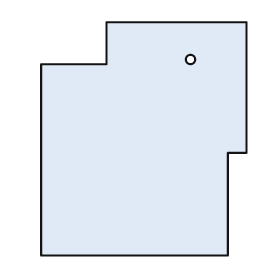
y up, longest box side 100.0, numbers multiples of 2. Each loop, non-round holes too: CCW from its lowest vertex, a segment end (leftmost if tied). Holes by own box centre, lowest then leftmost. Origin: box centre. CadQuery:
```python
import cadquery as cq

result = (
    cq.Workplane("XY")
    .moveTo(-44.0, -50.0)
    .lineTo(36.0, -50.0)
    .lineTo(36.0, -6.0)
    .lineTo(44.0, -6.0)
    .lineTo(44.0, 50.0)
    .lineTo(-16.0, 50.0)
    .lineTo(-16.0, 32.0)
    .lineTo(-44.0, 32.0)
    .close()
    .moveTo(20.0, 34.0)
    .circle(2.0)
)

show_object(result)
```